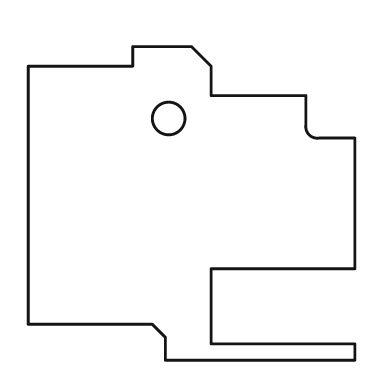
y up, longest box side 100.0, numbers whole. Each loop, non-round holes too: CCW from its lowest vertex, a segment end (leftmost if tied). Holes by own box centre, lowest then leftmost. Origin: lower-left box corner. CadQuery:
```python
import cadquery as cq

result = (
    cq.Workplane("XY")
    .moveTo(42.0, 0.0)
    .lineTo(100.0, 0.0)
    .lineTo(100.0, 5.0)
    .lineTo(56.0, 5.0)
    .lineTo(56.0, 28.0)
    .lineTo(100.0, 28.0)
    .lineTo(100.0, 68.0)
    .lineTo(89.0, 68.0)
    .threePointArc((86.0, 69.0), (85.0, 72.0))
    .lineTo(85.0, 81.0)
    .lineTo(56.0, 81.0)
    .lineTo(56.0, 90.0)
    .lineTo(50.0, 96.0)
    .lineTo(32.0, 96.0)
    .lineTo(32.0, 90.0)
    .lineTo(0.0, 90.0)
    .lineTo(0.0, 11.0)
    .lineTo(38.0, 11.0)
    .lineTo(42.0, 7.0)
    .close()
    .moveTo(43.0, 74.0)
    .circle(5.0)
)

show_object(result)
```